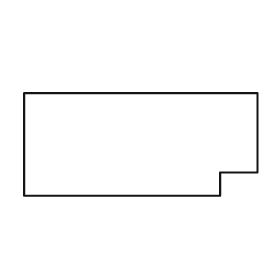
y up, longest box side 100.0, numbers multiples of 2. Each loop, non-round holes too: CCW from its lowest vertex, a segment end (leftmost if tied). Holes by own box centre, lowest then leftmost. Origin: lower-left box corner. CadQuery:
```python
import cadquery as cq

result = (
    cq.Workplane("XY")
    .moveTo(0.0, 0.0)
    .lineTo(84.0, 0.0)
    .lineTo(84.0, 10.0)
    .lineTo(100.0, 10.0)
    .lineTo(100.0, 44.0)
    .lineTo(0.0, 44.0)
    .close()
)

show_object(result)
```